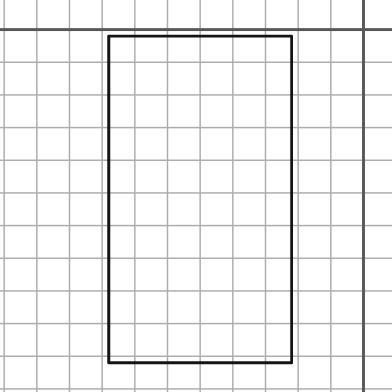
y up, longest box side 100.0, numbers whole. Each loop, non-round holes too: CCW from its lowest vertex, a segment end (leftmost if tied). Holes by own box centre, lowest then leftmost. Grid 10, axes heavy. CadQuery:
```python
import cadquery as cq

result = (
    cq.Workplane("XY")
    .moveTo(-78.0, -102.0)
    .lineTo(-22.0, -102.0)
    .lineTo(-22.0, -2.0)
    .lineTo(-78.0, -2.0)
    .close()
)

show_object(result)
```